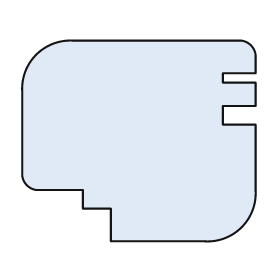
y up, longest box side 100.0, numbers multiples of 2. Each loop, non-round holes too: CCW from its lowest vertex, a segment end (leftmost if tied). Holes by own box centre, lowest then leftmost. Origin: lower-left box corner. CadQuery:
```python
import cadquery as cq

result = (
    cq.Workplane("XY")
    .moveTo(38.0, 0.0)
    .lineTo(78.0, 0.0)
    .threePointArc((94.0, 6.0), (100.0, 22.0))
    .lineTo(100.0, 50.0)
    .lineTo(86.0, 50.0)
    .lineTo(86.0, 58.0)
    .lineTo(100.0, 58.0)
    .lineTo(100.0, 68.0)
    .lineTo(86.0, 68.0)
    .lineTo(86.0, 72.0)
    .lineTo(100.0, 72.0)
    .lineTo(100.0, 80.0)
    .threePointArc((98.0, 84.0), (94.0, 86.0))
    .lineTo(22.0, 86.0)
    .threePointArc((6.0, 80.0), (0.0, 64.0))
    .lineTo(0.0, 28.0)
    .threePointArc((2.0, 24.0), (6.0, 22.0))
    .lineTo(26.0, 22.0)
    .lineTo(26.0, 14.0)
    .lineTo(38.0, 14.0)
    .close()
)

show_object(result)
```